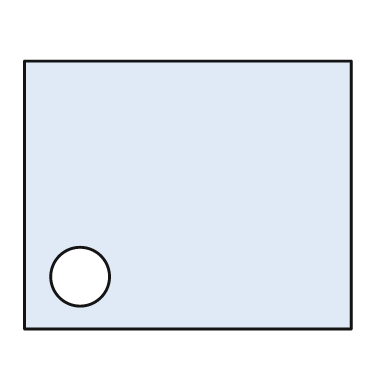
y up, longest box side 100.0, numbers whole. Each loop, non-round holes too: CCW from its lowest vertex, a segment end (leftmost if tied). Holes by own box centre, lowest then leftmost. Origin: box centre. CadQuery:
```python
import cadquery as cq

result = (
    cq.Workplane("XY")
    .moveTo(-50.0, -41.0)
    .lineTo(50.0, -41.0)
    .lineTo(50.0, 41.0)
    .lineTo(-50.0, 41.0)
    .close()
    .moveTo(-33.0, -25.0)
    .circle(9.0)
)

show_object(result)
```